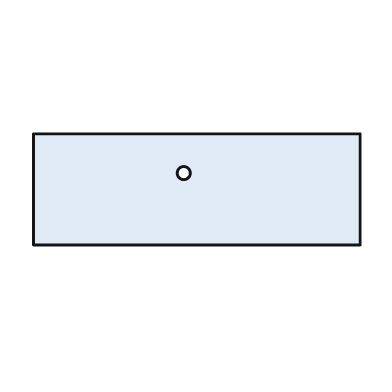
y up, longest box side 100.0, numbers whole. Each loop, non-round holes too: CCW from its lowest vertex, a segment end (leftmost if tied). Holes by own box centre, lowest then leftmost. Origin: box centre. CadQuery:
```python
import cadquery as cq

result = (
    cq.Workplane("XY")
    .moveTo(-50.0, -17.0)
    .lineTo(50.0, -17.0)
    .lineTo(50.0, 17.0)
    .lineTo(-50.0, 17.0)
    .close()
    .moveTo(-4.0, 5.0)
    .circle(2.0)
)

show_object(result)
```